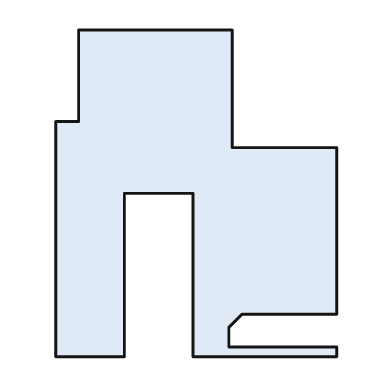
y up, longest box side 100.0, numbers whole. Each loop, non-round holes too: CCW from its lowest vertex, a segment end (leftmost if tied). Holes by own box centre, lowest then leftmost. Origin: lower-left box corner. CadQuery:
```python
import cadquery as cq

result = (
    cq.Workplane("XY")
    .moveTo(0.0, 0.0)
    .lineTo(21.0, 0.0)
    .lineTo(21.0, 50.0)
    .lineTo(42.0, 50.0)
    .lineTo(42.0, 0.0)
    .lineTo(86.0, 0.0)
    .lineTo(86.0, 3.0)
    .lineTo(53.0, 3.0)
    .lineTo(53.0, 9.0)
    .lineTo(57.0, 13.0)
    .lineTo(86.0, 13.0)
    .lineTo(86.0, 64.0)
    .lineTo(54.0, 64.0)
    .lineTo(54.0, 100.0)
    .lineTo(7.0, 100.0)
    .lineTo(7.0, 72.0)
    .lineTo(0.0, 72.0)
    .close()
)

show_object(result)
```